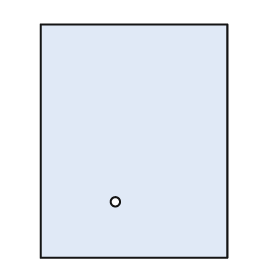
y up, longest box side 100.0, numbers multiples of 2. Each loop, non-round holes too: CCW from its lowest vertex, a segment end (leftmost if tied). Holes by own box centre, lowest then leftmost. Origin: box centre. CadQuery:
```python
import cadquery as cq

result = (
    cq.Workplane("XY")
    .moveTo(-40.0, -50.0)
    .lineTo(40.0, -50.0)
    .lineTo(40.0, 50.0)
    .lineTo(-40.0, 50.0)
    .close()
    .moveTo(-8.0, -26.0)
    .circle(2.0)
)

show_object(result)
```